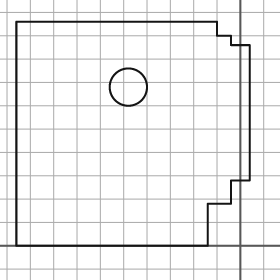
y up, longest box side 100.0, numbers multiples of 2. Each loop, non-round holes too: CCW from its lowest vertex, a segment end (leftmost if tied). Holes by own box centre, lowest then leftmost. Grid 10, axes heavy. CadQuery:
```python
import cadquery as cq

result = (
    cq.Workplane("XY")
    .moveTo(-96.0, 0.0)
    .lineTo(-14.0, 0.0)
    .lineTo(-14.0, 18.0)
    .lineTo(-4.0, 18.0)
    .lineTo(-4.0, 28.0)
    .lineTo(4.0, 28.0)
    .lineTo(4.0, 86.0)
    .lineTo(-4.0, 86.0)
    .lineTo(-4.0, 90.0)
    .lineTo(-10.0, 90.0)
    .lineTo(-10.0, 96.0)
    .lineTo(-96.0, 96.0)
    .close()
    .moveTo(-48.0, 68.0)
    .circle(8.0)
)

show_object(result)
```